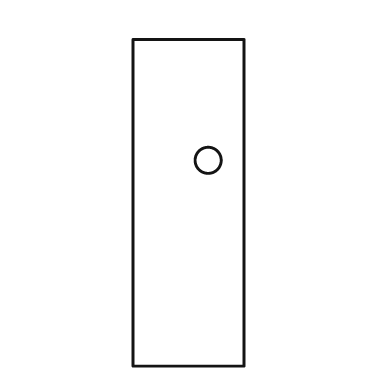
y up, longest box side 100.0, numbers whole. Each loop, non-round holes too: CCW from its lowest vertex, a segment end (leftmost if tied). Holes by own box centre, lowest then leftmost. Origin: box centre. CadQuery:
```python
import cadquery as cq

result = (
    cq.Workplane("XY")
    .moveTo(-17.0, -50.0)
    .lineTo(17.0, -50.0)
    .lineTo(17.0, 50.0)
    .lineTo(-17.0, 50.0)
    .close()
    .moveTo(6.0, 13.0)
    .circle(4.0)
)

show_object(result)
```